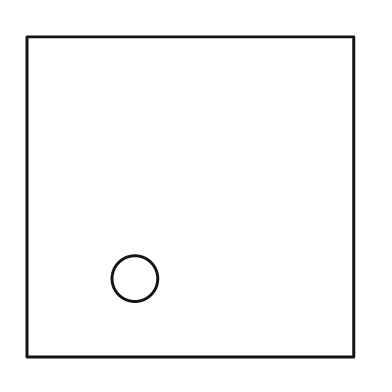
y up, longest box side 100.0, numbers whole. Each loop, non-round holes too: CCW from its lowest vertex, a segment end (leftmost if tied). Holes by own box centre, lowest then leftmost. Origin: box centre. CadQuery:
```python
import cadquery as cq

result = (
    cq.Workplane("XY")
    .moveTo(-50.0, -49.0)
    .lineTo(50.0, -49.0)
    .lineTo(50.0, 49.0)
    .lineTo(-50.0, 49.0)
    .close()
    .moveTo(-17.0, -25.0)
    .circle(7.0)
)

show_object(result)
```